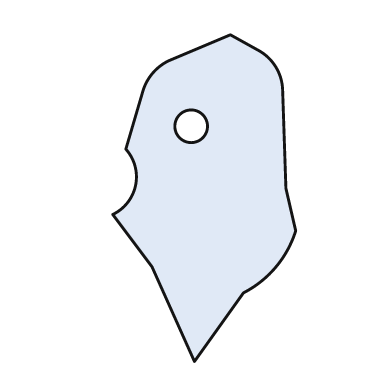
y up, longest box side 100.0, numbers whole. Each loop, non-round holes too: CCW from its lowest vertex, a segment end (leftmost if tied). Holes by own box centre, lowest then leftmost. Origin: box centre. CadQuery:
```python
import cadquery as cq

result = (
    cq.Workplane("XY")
    .moveTo(-3.0, -50.0)
    .lineTo(12.0, -29.0)
    .threePointArc((22.0, -21.0), (28.0, -10.0))
    .lineTo(25.0, 3.0)
    .lineTo(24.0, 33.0)
    .threePointArc((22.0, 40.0), (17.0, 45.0))
    .lineTo(8.0, 50.0)
    .lineTo(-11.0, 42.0)
    .threePointArc((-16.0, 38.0), (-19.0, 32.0))
    .lineTo(-24.0, 15.0)
    .threePointArc((-21.0, 4.0), (-28.0, -5.0))
    .lineTo(-16.0, -21.0)
    .close()
    .moveTo(-4.0, 22.0)
    .circle(5.0)
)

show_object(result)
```